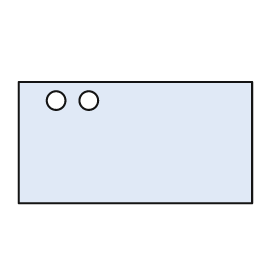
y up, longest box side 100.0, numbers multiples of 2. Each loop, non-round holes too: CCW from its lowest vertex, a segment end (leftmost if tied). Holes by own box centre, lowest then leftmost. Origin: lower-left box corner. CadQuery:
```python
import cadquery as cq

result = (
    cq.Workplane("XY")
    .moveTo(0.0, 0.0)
    .lineTo(100.0, 0.0)
    .lineTo(100.0, 52.0)
    .lineTo(0.0, 52.0)
    .close()
    .moveTo(16.0, 44.0)
    .circle(4.0)
    .moveTo(30.0, 44.0)
    .circle(4.0)
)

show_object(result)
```